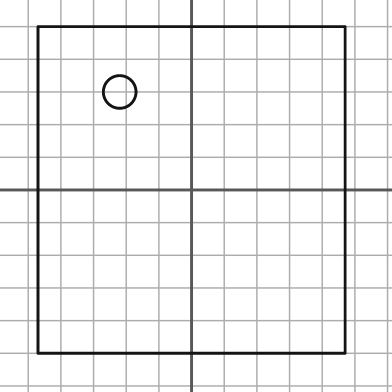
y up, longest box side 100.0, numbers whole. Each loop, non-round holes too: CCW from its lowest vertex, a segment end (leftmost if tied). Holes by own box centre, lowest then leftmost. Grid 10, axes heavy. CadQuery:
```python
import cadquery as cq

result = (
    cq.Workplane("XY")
    .moveTo(-47.0, -50.0)
    .lineTo(47.0, -50.0)
    .lineTo(47.0, 50.0)
    .lineTo(-47.0, 50.0)
    .close()
    .moveTo(-22.0, 30.0)
    .circle(5.0)
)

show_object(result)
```